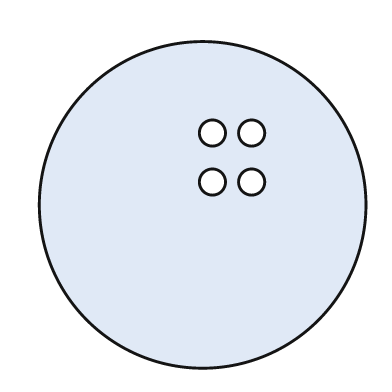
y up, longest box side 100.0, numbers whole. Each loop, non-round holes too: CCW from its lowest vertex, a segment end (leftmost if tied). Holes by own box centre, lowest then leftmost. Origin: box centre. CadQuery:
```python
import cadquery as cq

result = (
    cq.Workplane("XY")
    .moveTo(0.0, 0.0)
    .circle(50.0)
    .moveTo(3.0, 7.0)
    .circle(4.0)
    .moveTo(15.0, 7.0)
    .circle(4.0)
    .moveTo(3.0, 22.0)
    .circle(4.0)
    .moveTo(15.0, 22.0)
    .circle(4.0)
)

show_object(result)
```